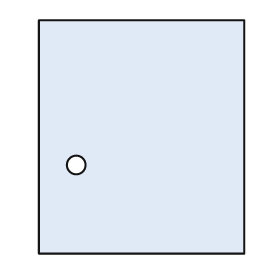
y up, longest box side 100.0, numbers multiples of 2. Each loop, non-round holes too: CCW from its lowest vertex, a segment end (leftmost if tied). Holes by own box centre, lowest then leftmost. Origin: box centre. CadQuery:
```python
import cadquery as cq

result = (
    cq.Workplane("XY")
    .moveTo(-44.0, -50.0)
    .lineTo(44.0, -50.0)
    .lineTo(44.0, 50.0)
    .lineTo(-44.0, 50.0)
    .close()
    .moveTo(-28.0, -12.0)
    .circle(4.0)
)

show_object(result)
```